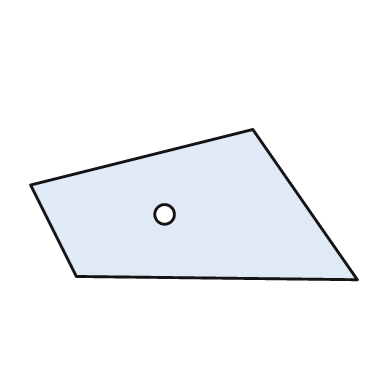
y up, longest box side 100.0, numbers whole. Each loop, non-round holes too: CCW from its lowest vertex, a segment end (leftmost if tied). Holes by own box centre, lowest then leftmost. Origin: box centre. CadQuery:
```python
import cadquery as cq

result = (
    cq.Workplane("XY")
    .moveTo(50.0, -23.0)
    .lineTo(18.0, 23.0)
    .lineTo(-50.0, 6.0)
    .lineTo(-36.0, -22.0)
    .close()
    .moveTo(-9.0, -3.0)
    .circle(3.0)
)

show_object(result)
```